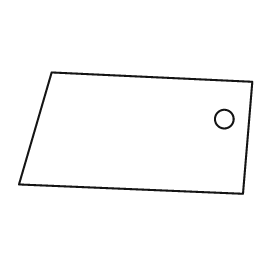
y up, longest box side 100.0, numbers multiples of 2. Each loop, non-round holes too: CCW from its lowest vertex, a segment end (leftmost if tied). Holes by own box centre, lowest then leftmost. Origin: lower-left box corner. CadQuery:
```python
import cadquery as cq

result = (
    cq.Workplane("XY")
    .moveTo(96.0, 0.0)
    .lineTo(100.0, 48.0)
    .lineTo(14.0, 52.0)
    .lineTo(0.0, 4.0)
    .close()
    .moveTo(88.0, 32.0)
    .circle(4.0)
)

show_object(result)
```